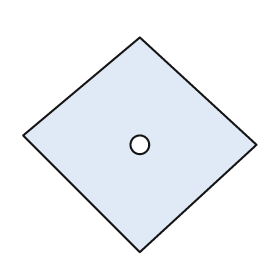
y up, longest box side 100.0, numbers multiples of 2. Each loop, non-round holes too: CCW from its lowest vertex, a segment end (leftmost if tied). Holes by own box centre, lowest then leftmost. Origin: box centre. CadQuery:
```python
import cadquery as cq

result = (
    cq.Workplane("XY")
    .moveTo(0.0, -46.0)
    .lineTo(50.0, 0.0)
    .lineTo(0.0, 46.0)
    .lineTo(-50.0, 4.0)
    .close()
    .moveTo(0.0, 0.0)
    .circle(4.0)
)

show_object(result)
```